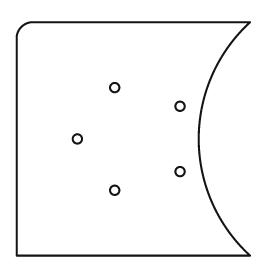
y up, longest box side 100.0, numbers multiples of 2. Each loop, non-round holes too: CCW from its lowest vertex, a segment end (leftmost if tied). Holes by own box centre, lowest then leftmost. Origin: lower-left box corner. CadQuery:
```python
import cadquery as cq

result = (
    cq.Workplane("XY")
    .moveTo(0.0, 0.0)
    .lineTo(100.0, 0.0)
    .threePointArc((78.0, 50.0), (100.0, 100.0))
    .lineTo(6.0, 100.0)
    .threePointArc((2.0, 98.0), (0.0, 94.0))
    .close()
    .moveTo(42.0, 28.0)
    .circle(2.0)
    .moveTo(70.0, 36.0)
    .circle(2.0)
    .moveTo(26.0, 50.0)
    .circle(2.0)
    .moveTo(70.0, 64.0)
    .circle(2.0)
    .moveTo(42.0, 72.0)
    .circle(2.0)
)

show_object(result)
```